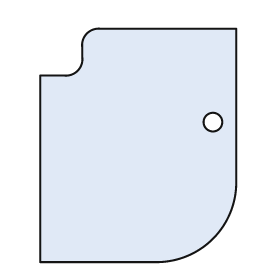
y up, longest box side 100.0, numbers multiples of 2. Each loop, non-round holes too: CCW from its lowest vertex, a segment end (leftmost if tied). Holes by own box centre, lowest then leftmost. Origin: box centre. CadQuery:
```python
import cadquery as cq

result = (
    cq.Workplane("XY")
    .moveTo(-42.0, -50.0)
    .lineTo(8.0, -50.0)
    .threePointArc((32.0, -40.0), (42.0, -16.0))
    .lineTo(42.0, 50.0)
    .lineTo(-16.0, 50.0)
    .threePointArc((-22.0, 48.0), (-24.0, 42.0))
    .lineTo(-24.0, 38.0)
    .threePointArc((-26.0, 32.0), (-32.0, 30.0))
    .lineTo(-42.0, 30.0)
    .close()
    .moveTo(32.0, 10.0)
    .circle(4.0)
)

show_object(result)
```